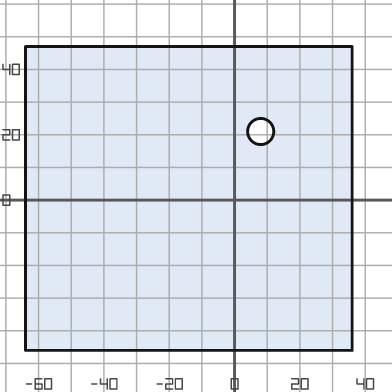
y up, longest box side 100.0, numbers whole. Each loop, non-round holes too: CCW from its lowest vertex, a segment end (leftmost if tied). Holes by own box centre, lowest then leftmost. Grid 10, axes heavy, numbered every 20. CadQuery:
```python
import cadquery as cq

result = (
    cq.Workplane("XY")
    .moveTo(-64.0, -46.0)
    .lineTo(36.0, -46.0)
    .lineTo(36.0, 47.0)
    .lineTo(-64.0, 47.0)
    .close()
    .moveTo(8.0, 21.0)
    .circle(4.0)
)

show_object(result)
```